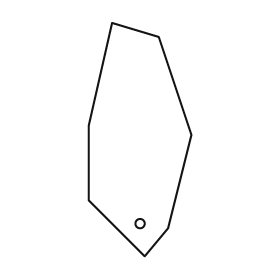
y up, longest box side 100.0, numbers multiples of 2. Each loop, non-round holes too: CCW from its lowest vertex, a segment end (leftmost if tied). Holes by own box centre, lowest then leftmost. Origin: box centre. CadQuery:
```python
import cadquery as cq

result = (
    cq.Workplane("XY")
    .moveTo(2.0, -50.0)
    .lineTo(12.0, -38.0)
    .lineTo(22.0, 2.0)
    .lineTo(8.0, 44.0)
    .lineTo(-12.0, 50.0)
    .lineTo(-22.0, 6.0)
    .lineTo(-22.0, -26.0)
    .close()
    .moveTo(0.0, -36.0)
    .circle(2.0)
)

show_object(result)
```